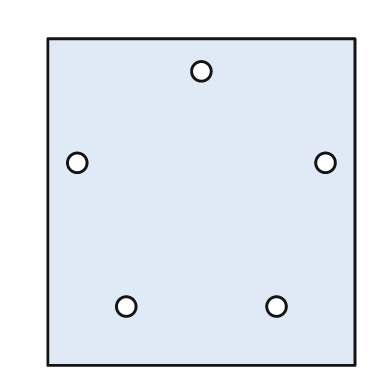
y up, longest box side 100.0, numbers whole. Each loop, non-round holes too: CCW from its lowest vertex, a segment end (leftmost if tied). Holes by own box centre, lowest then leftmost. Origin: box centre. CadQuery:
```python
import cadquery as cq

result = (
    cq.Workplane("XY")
    .moveTo(-47.0, -50.0)
    .lineTo(47.0, -50.0)
    .lineTo(47.0, 50.0)
    .lineTo(-47.0, 50.0)
    .close()
    .moveTo(-23.0, -32.0)
    .circle(3.0)
    .moveTo(23.0, -32.0)
    .circle(3.0)
    .moveTo(-38.0, 12.0)
    .circle(3.0)
    .moveTo(38.0, 12.0)
    .circle(3.0)
    .moveTo(0.0, 40.0)
    .circle(3.0)
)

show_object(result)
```